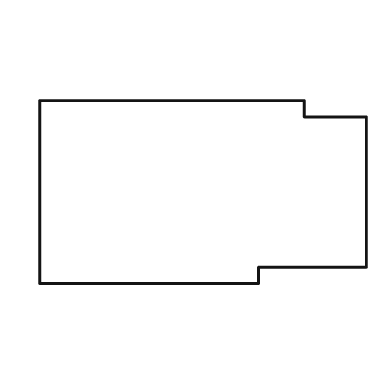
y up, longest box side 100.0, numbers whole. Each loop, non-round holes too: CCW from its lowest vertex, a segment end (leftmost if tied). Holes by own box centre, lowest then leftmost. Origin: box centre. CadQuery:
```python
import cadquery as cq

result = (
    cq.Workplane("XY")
    .moveTo(-50.0, -28.0)
    .lineTo(17.0, -28.0)
    .lineTo(17.0, -23.0)
    .lineTo(50.0, -23.0)
    .lineTo(50.0, 23.0)
    .lineTo(31.0, 23.0)
    .lineTo(31.0, 28.0)
    .lineTo(-50.0, 28.0)
    .close()
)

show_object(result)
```